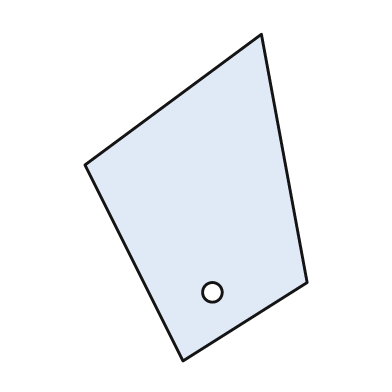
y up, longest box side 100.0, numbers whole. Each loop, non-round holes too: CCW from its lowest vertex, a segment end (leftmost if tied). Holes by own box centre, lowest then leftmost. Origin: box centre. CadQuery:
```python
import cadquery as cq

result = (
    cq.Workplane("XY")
    .moveTo(-4.0, -50.0)
    .lineTo(34.0, -26.0)
    .lineTo(20.0, 50.0)
    .lineTo(-34.0, 10.0)
    .close()
    .moveTo(5.0, -29.0)
    .circle(3.0)
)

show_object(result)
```